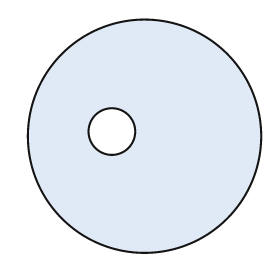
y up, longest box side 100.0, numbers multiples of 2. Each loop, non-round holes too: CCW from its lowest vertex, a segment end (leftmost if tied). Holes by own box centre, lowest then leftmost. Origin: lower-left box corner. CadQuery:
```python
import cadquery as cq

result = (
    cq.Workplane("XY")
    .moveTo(50.0, 50.0)
    .circle(50.0)
    .moveTo(36.0, 52.0)
    .circle(10.0)
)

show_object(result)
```